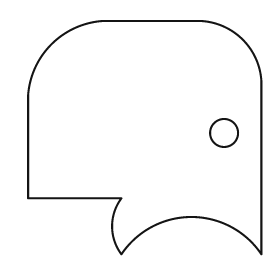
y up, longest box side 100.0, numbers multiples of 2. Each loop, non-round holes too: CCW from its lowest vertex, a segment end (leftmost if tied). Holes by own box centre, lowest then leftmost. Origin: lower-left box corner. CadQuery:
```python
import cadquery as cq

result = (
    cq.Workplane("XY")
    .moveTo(40.0, 0.0)
    .threePointArc((70.0, 16.0), (100.0, 0.0))
    .lineTo(100.0, 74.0)
    .threePointArc((92.0, 92.0), (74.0, 100.0))
    .lineTo(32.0, 100.0)
    .threePointArc((10.0, 90.0), (0.0, 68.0))
    .lineTo(0.0, 24.0)
    .lineTo(40.0, 24.0)
    .threePointArc((36.0, 12.0), (40.0, 0.0))
    .close()
    .moveTo(84.0, 52.0)
    .circle(6.0)
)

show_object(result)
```